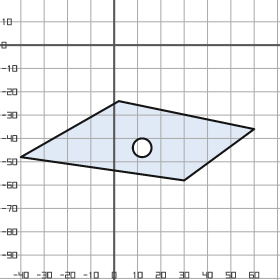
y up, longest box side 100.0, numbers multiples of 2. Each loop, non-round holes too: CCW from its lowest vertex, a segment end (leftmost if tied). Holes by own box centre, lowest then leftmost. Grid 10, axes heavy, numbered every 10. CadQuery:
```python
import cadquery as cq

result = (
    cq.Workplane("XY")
    .moveTo(30.0, -58.0)
    .lineTo(60.0, -36.0)
    .lineTo(2.0, -24.0)
    .lineTo(-40.0, -48.0)
    .close()
    .moveTo(12.0, -44.0)
    .circle(4.0)
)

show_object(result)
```